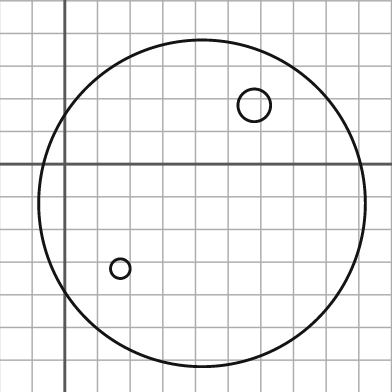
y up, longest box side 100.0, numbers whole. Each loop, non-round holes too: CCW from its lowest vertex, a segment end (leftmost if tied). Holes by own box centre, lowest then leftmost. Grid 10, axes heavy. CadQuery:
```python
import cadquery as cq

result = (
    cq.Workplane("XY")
    .moveTo(42.0, -12.0)
    .circle(50.0)
    .moveTo(17.0, -32.0)
    .circle(3.0)
    .moveTo(58.0, 18.0)
    .circle(5.0)
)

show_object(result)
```